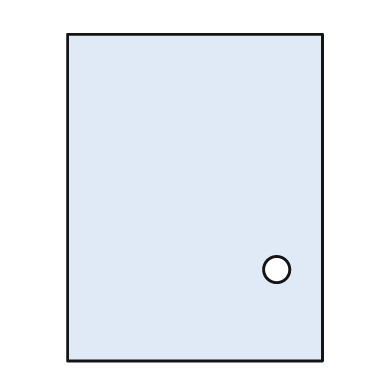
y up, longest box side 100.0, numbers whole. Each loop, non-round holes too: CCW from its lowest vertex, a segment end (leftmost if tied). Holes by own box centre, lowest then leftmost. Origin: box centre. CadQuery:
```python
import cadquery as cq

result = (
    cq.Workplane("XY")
    .moveTo(-39.0, -50.0)
    .lineTo(39.0, -50.0)
    .lineTo(39.0, 50.0)
    .lineTo(-39.0, 50.0)
    .close()
    .moveTo(25.0, -22.0)
    .circle(4.0)
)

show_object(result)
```